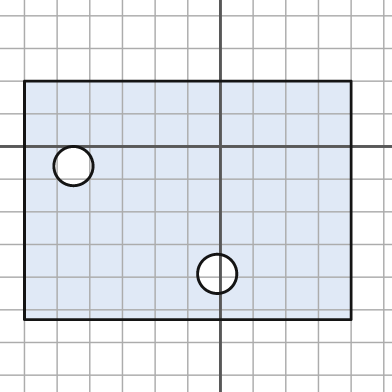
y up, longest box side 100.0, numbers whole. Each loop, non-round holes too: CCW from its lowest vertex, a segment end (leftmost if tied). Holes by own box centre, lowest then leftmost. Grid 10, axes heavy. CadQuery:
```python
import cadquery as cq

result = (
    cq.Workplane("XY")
    .moveTo(-60.0, -53.0)
    .lineTo(40.0, -53.0)
    .lineTo(40.0, 20.0)
    .lineTo(-60.0, 20.0)
    .close()
    .moveTo(-1.0, -39.0)
    .circle(6.0)
    .moveTo(-45.0, -6.0)
    .circle(6.0)
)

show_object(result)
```